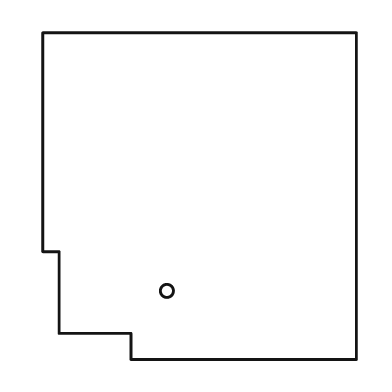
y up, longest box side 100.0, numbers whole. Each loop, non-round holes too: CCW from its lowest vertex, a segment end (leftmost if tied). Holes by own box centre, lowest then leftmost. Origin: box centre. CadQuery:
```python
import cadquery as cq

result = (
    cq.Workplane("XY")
    .moveTo(-21.0, -50.0)
    .lineTo(48.0, -50.0)
    .lineTo(48.0, 50.0)
    .lineTo(-48.0, 50.0)
    .lineTo(-48.0, -17.0)
    .lineTo(-43.0, -17.0)
    .lineTo(-43.0, -42.0)
    .lineTo(-21.0, -42.0)
    .close()
    .moveTo(-10.0, -29.0)
    .circle(2.0)
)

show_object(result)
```